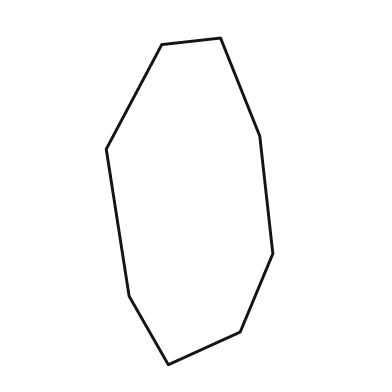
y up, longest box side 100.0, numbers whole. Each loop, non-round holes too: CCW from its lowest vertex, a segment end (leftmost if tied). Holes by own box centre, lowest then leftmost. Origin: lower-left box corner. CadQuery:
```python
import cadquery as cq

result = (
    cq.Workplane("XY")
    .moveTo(19.0, 0.0)
    .lineTo(41.0, 10.0)
    .lineTo(51.0, 34.0)
    .lineTo(47.0, 70.0)
    .lineTo(35.0, 100.0)
    .lineTo(17.0, 98.0)
    .lineTo(0.0, 66.0)
    .lineTo(7.0, 21.0)
    .close()
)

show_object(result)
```